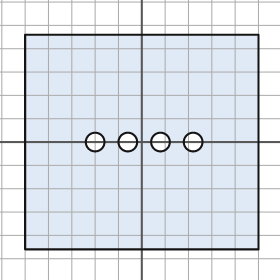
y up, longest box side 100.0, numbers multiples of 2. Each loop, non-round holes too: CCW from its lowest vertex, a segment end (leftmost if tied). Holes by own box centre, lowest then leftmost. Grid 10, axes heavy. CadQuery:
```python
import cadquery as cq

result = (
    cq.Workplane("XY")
    .moveTo(-50.0, -46.0)
    .lineTo(50.0, -46.0)
    .lineTo(50.0, 46.0)
    .lineTo(-50.0, 46.0)
    .close()
    .moveTo(-20.0, 0.0)
    .circle(4.0)
    .moveTo(-6.0, 0.0)
    .circle(4.0)
    .moveTo(8.0, 0.0)
    .circle(4.0)
    .moveTo(22.0, 0.0)
    .circle(4.0)
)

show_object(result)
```